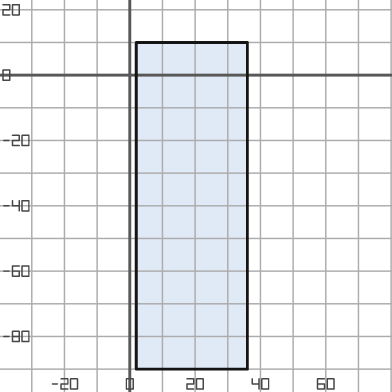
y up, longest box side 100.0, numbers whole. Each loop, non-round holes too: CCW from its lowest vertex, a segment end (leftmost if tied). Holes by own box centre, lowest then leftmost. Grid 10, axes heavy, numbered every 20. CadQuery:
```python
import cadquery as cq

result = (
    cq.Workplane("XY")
    .moveTo(2.0, -90.0)
    .lineTo(36.0, -90.0)
    .lineTo(36.0, 10.0)
    .lineTo(2.0, 10.0)
    .close()
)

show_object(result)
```